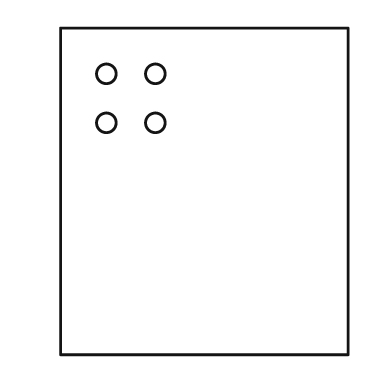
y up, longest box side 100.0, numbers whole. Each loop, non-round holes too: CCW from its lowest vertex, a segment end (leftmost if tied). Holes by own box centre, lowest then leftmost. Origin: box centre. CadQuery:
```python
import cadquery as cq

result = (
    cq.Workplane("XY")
    .moveTo(-44.0, -50.0)
    .lineTo(44.0, -50.0)
    .lineTo(44.0, 50.0)
    .lineTo(-44.0, 50.0)
    .close()
    .moveTo(-30.0, 21.0)
    .circle(3.0)
    .moveTo(-15.0, 21.0)
    .circle(3.0)
    .moveTo(-30.0, 36.0)
    .circle(3.0)
    .moveTo(-15.0, 36.0)
    .circle(3.0)
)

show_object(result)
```